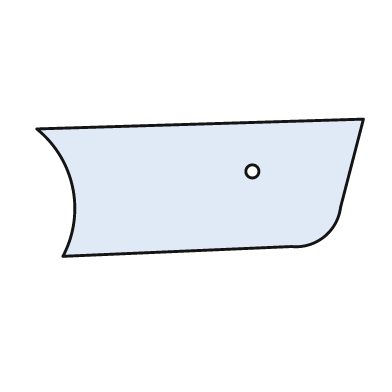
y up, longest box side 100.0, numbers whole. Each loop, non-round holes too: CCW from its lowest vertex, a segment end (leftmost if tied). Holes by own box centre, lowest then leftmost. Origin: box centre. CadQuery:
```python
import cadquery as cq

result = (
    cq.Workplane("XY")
    .moveTo(-42.0, -21.0)
    .lineTo(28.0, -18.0)
    .threePointArc((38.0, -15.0), (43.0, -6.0))
    .lineTo(50.0, 21.0)
    .lineTo(-50.0, 18.0)
    .threePointArc((-39.0, 0.0), (-42.0, -21.0))
    .close()
    .moveTo(16.0, 5.0)
    .circle(2.0)
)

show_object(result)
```